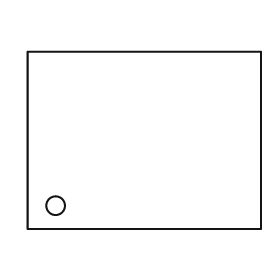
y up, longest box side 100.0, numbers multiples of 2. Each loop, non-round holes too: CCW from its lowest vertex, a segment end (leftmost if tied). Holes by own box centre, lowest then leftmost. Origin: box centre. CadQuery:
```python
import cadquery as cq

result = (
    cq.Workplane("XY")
    .moveTo(-50.0, -38.0)
    .lineTo(50.0, -38.0)
    .lineTo(50.0, 38.0)
    .lineTo(-50.0, 38.0)
    .close()
    .moveTo(-38.0, -28.0)
    .circle(4.0)
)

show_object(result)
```